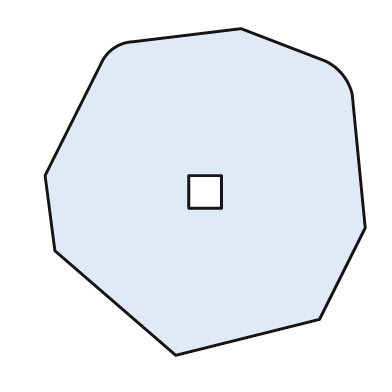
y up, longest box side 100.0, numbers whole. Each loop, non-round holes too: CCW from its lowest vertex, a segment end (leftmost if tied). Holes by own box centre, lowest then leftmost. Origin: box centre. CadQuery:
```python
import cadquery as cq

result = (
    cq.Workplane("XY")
    .moveTo(-9.0, -50.0)
    .lineTo(35.0, -39.0)
    .lineTo(49.0, -11.0)
    .lineTo(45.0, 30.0)
    .threePointArc((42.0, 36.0), (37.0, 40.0))
    .lineTo(11.0, 50.0)
    .lineTo(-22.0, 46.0)
    .threePointArc((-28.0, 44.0), (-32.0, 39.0))
    .lineTo(-49.0, 5.0)
    .lineTo(-46.0, -18.0)
    .close()
    .moveTo(-5.0, -5.0)
    .lineTo(5.0, -5.0)
    .lineTo(5.0, 5.0)
    .lineTo(-5.0, 5.0)
    .close()
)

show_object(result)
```